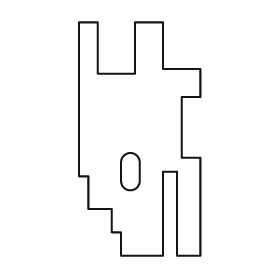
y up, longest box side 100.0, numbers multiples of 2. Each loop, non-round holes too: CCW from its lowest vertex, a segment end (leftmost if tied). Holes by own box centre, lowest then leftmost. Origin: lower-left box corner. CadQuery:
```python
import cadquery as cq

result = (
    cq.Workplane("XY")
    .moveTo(18.0, 0.0)
    .lineTo(36.0, 0.0)
    .lineTo(36.0, 36.0)
    .lineTo(42.0, 36.0)
    .lineTo(42.0, 0.0)
    .lineTo(52.0, 0.0)
    .lineTo(52.0, 42.0)
    .lineTo(44.0, 42.0)
    .lineTo(44.0, 68.0)
    .lineTo(52.0, 68.0)
    .lineTo(52.0, 80.0)
    .lineTo(36.0, 80.0)
    .lineTo(36.0, 100.0)
    .lineTo(24.0, 100.0)
    .lineTo(24.0, 78.0)
    .lineTo(8.0, 78.0)
    .lineTo(8.0, 100.0)
    .lineTo(0.0, 100.0)
    .lineTo(0.0, 34.0)
    .lineTo(4.0, 34.0)
    .lineTo(4.0, 20.0)
    .lineTo(14.0, 20.0)
    .lineTo(14.0, 10.0)
    .lineTo(18.0, 10.0)
    .close()
    .moveTo(18.0, 32.0)
    .threePointArc((22.0, 28.0), (26.0, 32.0))
    .lineTo(26.0, 40.0)
    .threePointArc((22.0, 44.0), (18.0, 40.0))
    .close()
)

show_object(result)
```